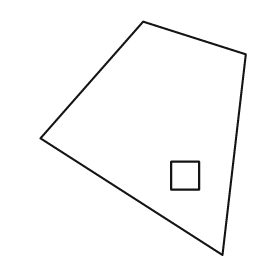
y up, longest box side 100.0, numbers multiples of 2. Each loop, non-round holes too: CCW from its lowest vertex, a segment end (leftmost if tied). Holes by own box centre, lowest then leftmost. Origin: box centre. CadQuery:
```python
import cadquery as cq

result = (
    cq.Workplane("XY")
    .moveTo(34.0, -50.0)
    .lineTo(44.0, 36.0)
    .lineTo(0.0, 50.0)
    .lineTo(-44.0, 0.0)
    .close()
    .moveTo(12.0, -22.0)
    .lineTo(24.0, -22.0)
    .lineTo(24.0, -10.0)
    .lineTo(12.0, -10.0)
    .close()
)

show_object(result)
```